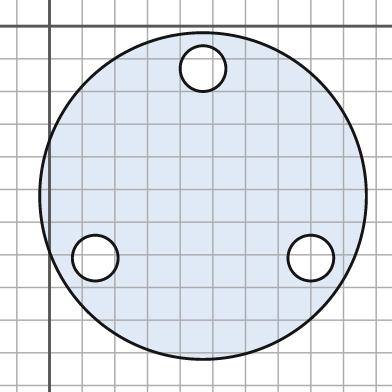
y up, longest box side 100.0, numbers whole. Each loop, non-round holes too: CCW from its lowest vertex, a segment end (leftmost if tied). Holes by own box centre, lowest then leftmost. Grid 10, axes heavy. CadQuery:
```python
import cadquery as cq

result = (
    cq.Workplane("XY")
    .moveTo(47.0, -52.0)
    .circle(50.0)
    .moveTo(14.0, -71.0)
    .circle(7.0)
    .moveTo(80.0, -71.0)
    .circle(7.0)
    .moveTo(47.0, -13.0)
    .circle(7.0)
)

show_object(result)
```